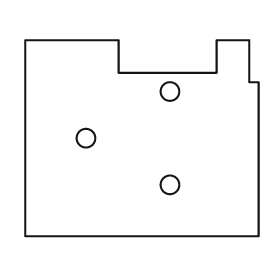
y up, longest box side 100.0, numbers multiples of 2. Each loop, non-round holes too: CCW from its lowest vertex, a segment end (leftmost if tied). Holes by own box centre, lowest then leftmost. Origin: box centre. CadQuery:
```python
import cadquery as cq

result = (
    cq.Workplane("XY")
    .moveTo(-50.0, -42.0)
    .lineTo(50.0, -42.0)
    .lineTo(50.0, 24.0)
    .lineTo(46.0, 24.0)
    .lineTo(46.0, 42.0)
    .lineTo(32.0, 42.0)
    .lineTo(32.0, 28.0)
    .lineTo(-10.0, 28.0)
    .lineTo(-10.0, 42.0)
    .lineTo(-50.0, 42.0)
    .close()
    .moveTo(12.0, -20.0)
    .circle(4.0)
    .moveTo(-24.0, 0.0)
    .circle(4.0)
    .moveTo(12.0, 20.0)
    .circle(4.0)
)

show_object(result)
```